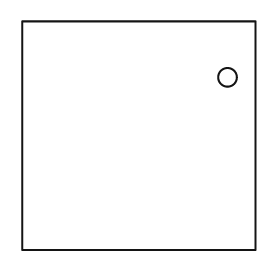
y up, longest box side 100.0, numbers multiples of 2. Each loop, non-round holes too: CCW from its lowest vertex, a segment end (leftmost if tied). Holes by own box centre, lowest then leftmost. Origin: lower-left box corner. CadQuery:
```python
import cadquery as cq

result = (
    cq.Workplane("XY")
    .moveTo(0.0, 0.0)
    .lineTo(100.0, 0.0)
    .lineTo(100.0, 98.0)
    .lineTo(0.0, 98.0)
    .close()
    .moveTo(88.0, 74.0)
    .circle(4.0)
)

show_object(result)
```